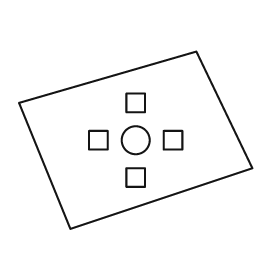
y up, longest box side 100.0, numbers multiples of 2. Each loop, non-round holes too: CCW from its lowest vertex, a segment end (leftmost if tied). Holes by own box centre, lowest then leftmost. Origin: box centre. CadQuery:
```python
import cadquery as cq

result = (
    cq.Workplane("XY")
    .moveTo(-28.0, -38.0)
    .lineTo(50.0, -12.0)
    .lineTo(26.0, 38.0)
    .lineTo(-50.0, 16.0)
    .close()
    .moveTo(-4.0, -20.0)
    .lineTo(4.0, -20.0)
    .lineTo(4.0, -12.0)
    .lineTo(-4.0, -12.0)
    .close()
    .moveTo(-20.0, -4.0)
    .lineTo(-12.0, -4.0)
    .lineTo(-12.0, 4.0)
    .lineTo(-20.0, 4.0)
    .close()
    .moveTo(0.0, 0.0)
    .circle(6.0)
    .moveTo(12.0, -4.0)
    .lineTo(20.0, -4.0)
    .lineTo(20.0, 4.0)
    .lineTo(12.0, 4.0)
    .close()
    .moveTo(-4.0, 12.0)
    .lineTo(4.0, 12.0)
    .lineTo(4.0, 20.0)
    .lineTo(-4.0, 20.0)
    .close()
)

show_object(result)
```